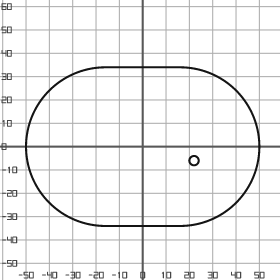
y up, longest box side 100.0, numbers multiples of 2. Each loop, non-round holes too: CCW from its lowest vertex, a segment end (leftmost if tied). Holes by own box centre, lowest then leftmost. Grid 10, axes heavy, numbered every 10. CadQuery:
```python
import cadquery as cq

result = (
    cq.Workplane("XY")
    .moveTo(-16.0, -34.0)
    .lineTo(16.0, -34.0)
    .threePointArc((50.0, 0.0), (16.0, 34.0))
    .lineTo(-16.0, 34.0)
    .threePointArc((-50.0, 0.0), (-16.0, -34.0))
    .close()
    .moveTo(22.0, -6.0)
    .circle(2.0)
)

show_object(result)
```